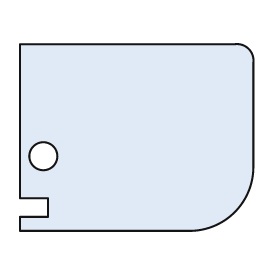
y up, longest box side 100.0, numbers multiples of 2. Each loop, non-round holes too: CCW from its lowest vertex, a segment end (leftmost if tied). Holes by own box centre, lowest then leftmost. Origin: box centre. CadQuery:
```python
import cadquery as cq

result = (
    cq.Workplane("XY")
    .moveTo(-50.0, -40.0)
    .lineTo(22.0, -40.0)
    .threePointArc((42.0, -32.0), (50.0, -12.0))
    .lineTo(50.0, 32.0)
    .threePointArc((48.0, 38.0), (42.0, 40.0))
    .lineTo(-50.0, 40.0)
    .lineTo(-50.0, -26.0)
    .lineTo(-38.0, -26.0)
    .lineTo(-38.0, -34.0)
    .lineTo(-50.0, -34.0)
    .close()
    .moveTo(-40.0, -8.0)
    .circle(6.0)
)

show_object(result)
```